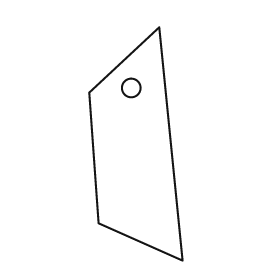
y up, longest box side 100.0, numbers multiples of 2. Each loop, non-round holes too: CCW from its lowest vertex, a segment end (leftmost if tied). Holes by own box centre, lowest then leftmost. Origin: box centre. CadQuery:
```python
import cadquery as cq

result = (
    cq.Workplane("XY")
    .moveTo(20.0, -50.0)
    .lineTo(10.0, 50.0)
    .lineTo(-20.0, 22.0)
    .lineTo(-16.0, -34.0)
    .close()
    .moveTo(-2.0, 24.0)
    .circle(4.0)
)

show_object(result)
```